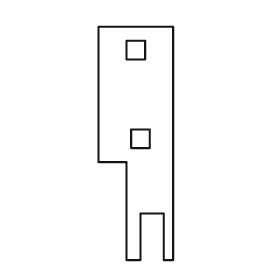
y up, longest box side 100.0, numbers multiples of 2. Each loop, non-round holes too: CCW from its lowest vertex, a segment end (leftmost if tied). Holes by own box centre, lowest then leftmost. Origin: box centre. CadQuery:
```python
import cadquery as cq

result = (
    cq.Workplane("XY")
    .moveTo(-4.0, -50.0)
    .lineTo(2.0, -50.0)
    .lineTo(2.0, -30.0)
    .lineTo(12.0, -30.0)
    .lineTo(12.0, -50.0)
    .lineTo(16.0, -50.0)
    .lineTo(16.0, 50.0)
    .lineTo(-16.0, 50.0)
    .lineTo(-16.0, -8.0)
    .lineTo(-4.0, -8.0)
    .close()
    .moveTo(-2.0, -2.0)
    .lineTo(6.0, -2.0)
    .lineTo(6.0, 6.0)
    .lineTo(-2.0, 6.0)
    .close()
    .moveTo(-4.0, 36.0)
    .lineTo(4.0, 36.0)
    .lineTo(4.0, 44.0)
    .lineTo(-4.0, 44.0)
    .close()
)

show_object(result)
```